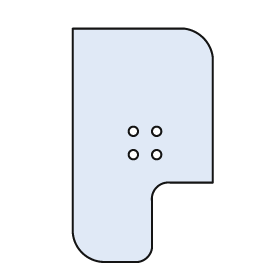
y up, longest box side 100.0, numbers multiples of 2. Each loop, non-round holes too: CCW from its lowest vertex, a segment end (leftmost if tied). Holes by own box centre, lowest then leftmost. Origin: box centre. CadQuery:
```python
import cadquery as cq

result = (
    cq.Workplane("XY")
    .moveTo(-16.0, -50.0)
    .lineTo(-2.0, -50.0)
    .threePointArc((2.0, -48.0), (4.0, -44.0))
    .lineTo(4.0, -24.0)
    .threePointArc((6.0, -18.0), (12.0, -16.0))
    .lineTo(30.0, -16.0)
    .lineTo(30.0, 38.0)
    .threePointArc((26.0, 46.0), (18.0, 50.0))
    .lineTo(-30.0, 50.0)
    .lineTo(-30.0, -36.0)
    .threePointArc((-26.0, -46.0), (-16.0, -50.0))
    .close()
    .moveTo(-4.0, -4.0)
    .circle(2.0)
    .moveTo(6.0, -4.0)
    .circle(2.0)
    .moveTo(-4.0, 6.0)
    .circle(2.0)
    .moveTo(6.0, 6.0)
    .circle(2.0)
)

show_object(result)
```